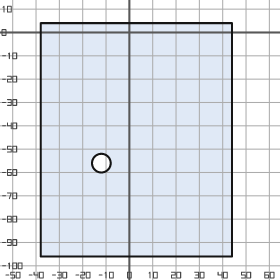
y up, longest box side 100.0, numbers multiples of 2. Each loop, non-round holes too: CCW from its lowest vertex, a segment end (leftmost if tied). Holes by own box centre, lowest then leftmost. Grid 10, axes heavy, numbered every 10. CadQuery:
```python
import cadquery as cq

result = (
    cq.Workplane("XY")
    .moveTo(-38.0, -96.0)
    .lineTo(44.0, -96.0)
    .lineTo(44.0, 4.0)
    .lineTo(-38.0, 4.0)
    .close()
    .moveTo(-12.0, -56.0)
    .circle(4.0)
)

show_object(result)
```